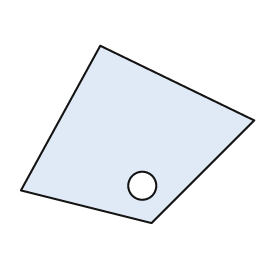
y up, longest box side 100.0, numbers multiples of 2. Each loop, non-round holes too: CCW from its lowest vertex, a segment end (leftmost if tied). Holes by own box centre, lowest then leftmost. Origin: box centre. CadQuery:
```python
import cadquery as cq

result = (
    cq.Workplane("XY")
    .moveTo(6.0, -38.0)
    .lineTo(50.0, 6.0)
    .lineTo(-16.0, 38.0)
    .lineTo(-50.0, -24.0)
    .close()
    .moveTo(2.0, -22.0)
    .circle(6.0)
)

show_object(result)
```